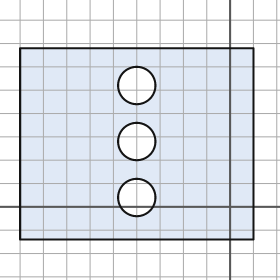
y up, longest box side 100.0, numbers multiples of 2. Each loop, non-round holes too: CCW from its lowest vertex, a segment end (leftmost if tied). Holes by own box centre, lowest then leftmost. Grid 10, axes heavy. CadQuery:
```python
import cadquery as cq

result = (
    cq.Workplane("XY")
    .moveTo(-90.0, -14.0)
    .lineTo(10.0, -14.0)
    .lineTo(10.0, 68.0)
    .lineTo(-90.0, 68.0)
    .close()
    .moveTo(-40.0, 4.0)
    .circle(8.0)
    .moveTo(-40.0, 28.0)
    .circle(8.0)
    .moveTo(-40.0, 52.0)
    .circle(8.0)
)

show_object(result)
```